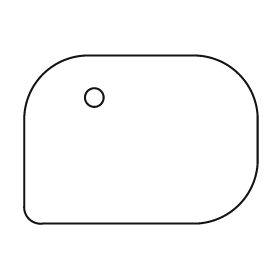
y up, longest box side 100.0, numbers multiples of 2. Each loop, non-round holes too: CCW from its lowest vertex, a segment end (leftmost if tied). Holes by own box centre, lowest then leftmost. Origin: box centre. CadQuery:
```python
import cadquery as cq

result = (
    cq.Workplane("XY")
    .moveTo(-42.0, -36.0)
    .lineTo(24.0, -36.0)
    .threePointArc((42.0, -28.0), (50.0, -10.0))
    .lineTo(50.0, 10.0)
    .threePointArc((42.0, 28.0), (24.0, 36.0))
    .lineTo(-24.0, 36.0)
    .threePointArc((-42.0, 28.0), (-50.0, 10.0))
    .lineTo(-50.0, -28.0)
    .threePointArc((-48.0, -34.0), (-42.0, -36.0))
    .close()
    .moveTo(-20.0, 18.0)
    .circle(4.0)
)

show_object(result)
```